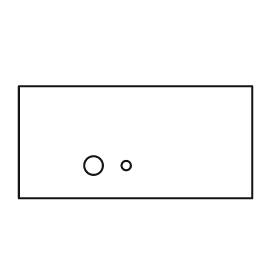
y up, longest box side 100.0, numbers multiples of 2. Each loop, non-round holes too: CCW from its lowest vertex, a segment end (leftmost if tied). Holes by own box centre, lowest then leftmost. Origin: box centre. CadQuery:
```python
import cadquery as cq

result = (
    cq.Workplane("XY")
    .moveTo(-50.0, -24.0)
    .lineTo(50.0, -24.0)
    .lineTo(50.0, 24.0)
    .lineTo(-50.0, 24.0)
    .close()
    .moveTo(-18.0, -10.0)
    .circle(4.0)
    .moveTo(-4.0, -10.0)
    .circle(2.0)
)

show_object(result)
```